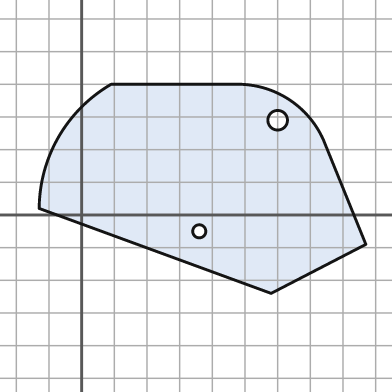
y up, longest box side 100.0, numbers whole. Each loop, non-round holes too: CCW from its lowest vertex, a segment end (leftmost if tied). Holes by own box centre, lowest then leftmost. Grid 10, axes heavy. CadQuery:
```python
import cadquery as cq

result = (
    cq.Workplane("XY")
    .moveTo(58.0, -24.0)
    .lineTo(87.0, -9.0)
    .lineTo(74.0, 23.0)
    .threePointArc((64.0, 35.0), (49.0, 40.0))
    .lineTo(9.0, 40.0)
    .threePointArc((-7.0, 24.0), (-13.0, 2.0))
    .close()
    .moveTo(36.0, -5.0)
    .circle(2.0)
    .moveTo(60.0, 29.0)
    .circle(3.0)
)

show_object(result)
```